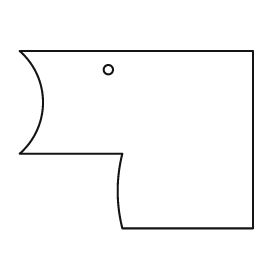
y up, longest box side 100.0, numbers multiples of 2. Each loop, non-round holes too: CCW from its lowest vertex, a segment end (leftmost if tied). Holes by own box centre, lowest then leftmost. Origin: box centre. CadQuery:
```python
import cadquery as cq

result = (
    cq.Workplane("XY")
    .moveTo(-6.0, -38.0)
    .lineTo(50.0, -38.0)
    .lineTo(50.0, 38.0)
    .lineTo(-50.0, 38.0)
    .threePointArc((-40.0, 16.0), (-50.0, -6.0))
    .lineTo(-6.0, -6.0)
    .threePointArc((-8.0, -22.0), (-6.0, -38.0))
    .close()
    .moveTo(-12.0, 30.0)
    .circle(2.0)
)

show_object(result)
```